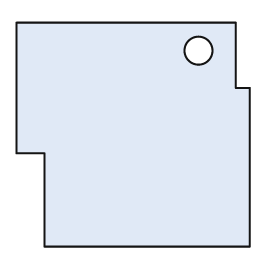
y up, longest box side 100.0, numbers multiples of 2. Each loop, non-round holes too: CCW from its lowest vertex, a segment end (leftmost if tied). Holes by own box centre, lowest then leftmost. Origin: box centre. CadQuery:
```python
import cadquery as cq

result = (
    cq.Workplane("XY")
    .moveTo(-38.0, -48.0)
    .lineTo(50.0, -48.0)
    .lineTo(50.0, 20.0)
    .lineTo(44.0, 20.0)
    .lineTo(44.0, 48.0)
    .lineTo(-50.0, 48.0)
    .lineTo(-50.0, -8.0)
    .lineTo(-38.0, -8.0)
    .close()
    .moveTo(28.0, 36.0)
    .circle(6.0)
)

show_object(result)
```